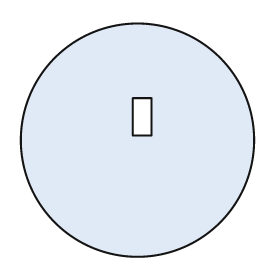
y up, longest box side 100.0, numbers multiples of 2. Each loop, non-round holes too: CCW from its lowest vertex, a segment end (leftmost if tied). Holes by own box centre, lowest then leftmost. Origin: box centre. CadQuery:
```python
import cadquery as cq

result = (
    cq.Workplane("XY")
    .moveTo(0.0, 0.0)
    .circle(50.0)
    .moveTo(-2.0, 2.0)
    .lineTo(6.0, 2.0)
    .lineTo(6.0, 18.0)
    .lineTo(-2.0, 18.0)
    .close()
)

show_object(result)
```